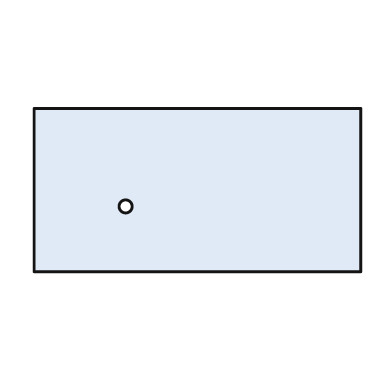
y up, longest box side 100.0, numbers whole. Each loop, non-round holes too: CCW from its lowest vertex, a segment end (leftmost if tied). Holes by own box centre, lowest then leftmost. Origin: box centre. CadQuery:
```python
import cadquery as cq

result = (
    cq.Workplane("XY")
    .moveTo(-50.0, -25.0)
    .lineTo(50.0, -25.0)
    .lineTo(50.0, 25.0)
    .lineTo(-50.0, 25.0)
    .close()
    .moveTo(-22.0, -5.0)
    .circle(2.0)
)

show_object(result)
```